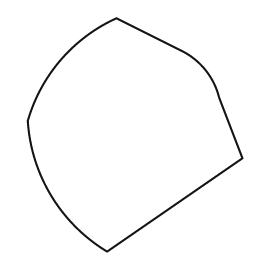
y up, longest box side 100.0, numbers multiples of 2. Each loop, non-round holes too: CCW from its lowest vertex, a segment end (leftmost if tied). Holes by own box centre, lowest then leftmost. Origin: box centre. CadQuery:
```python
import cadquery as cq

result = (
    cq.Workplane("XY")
    .moveTo(-12.0, -50.0)
    .lineTo(46.0, -10.0)
    .lineTo(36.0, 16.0)
    .threePointArc((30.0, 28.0), (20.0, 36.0))
    .lineTo(-8.0, 50.0)
    .threePointArc((-32.0, 32.0), (-46.0, 6.0))
    .threePointArc((-36.0, -26.0), (-12.0, -50.0))
    .close()
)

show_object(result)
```